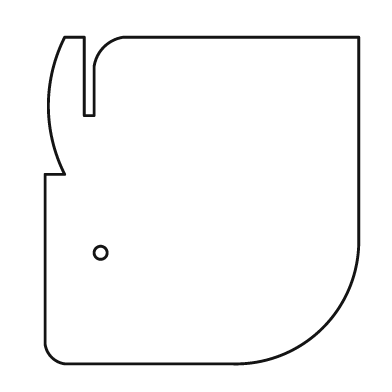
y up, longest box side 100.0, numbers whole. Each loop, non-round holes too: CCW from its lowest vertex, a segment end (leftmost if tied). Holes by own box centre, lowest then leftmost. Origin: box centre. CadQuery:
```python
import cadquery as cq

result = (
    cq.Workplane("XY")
    .moveTo(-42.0, -50.0)
    .lineTo(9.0, -50.0)
    .threePointArc((37.0, -39.0), (48.0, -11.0))
    .lineTo(48.0, 50.0)
    .lineTo(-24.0, 50.0)
    .threePointArc((-30.0, 47.0), (-33.0, 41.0))
    .lineTo(-33.0, 26.0)
    .lineTo(-36.0, 26.0)
    .lineTo(-36.0, 50.0)
    .lineTo(-42.0, 50.0)
    .threePointArc((-47.0, 29.0), (-42.0, 8.0))
    .lineTo(-48.0, 8.0)
    .lineTo(-48.0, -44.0)
    .threePointArc((-46.0, -48.0), (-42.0, -50.0))
    .close()
    .moveTo(-31.0, -16.0)
    .circle(2.0)
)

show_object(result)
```